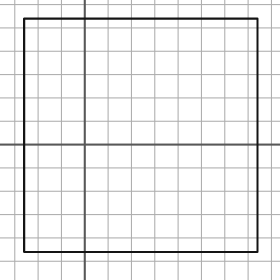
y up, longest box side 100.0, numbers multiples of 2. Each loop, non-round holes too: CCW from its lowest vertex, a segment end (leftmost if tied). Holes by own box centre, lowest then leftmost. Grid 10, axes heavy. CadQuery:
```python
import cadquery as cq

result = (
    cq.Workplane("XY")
    .moveTo(-26.0, -46.0)
    .lineTo(74.0, -46.0)
    .lineTo(74.0, 54.0)
    .lineTo(-26.0, 54.0)
    .close()
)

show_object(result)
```